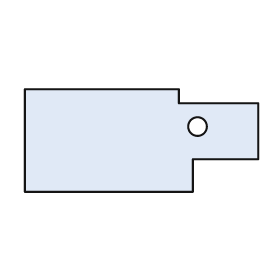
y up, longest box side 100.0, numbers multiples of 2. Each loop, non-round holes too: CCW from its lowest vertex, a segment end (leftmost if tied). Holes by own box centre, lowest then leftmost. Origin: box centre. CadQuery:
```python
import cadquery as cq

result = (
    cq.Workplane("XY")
    .moveTo(-50.0, -22.0)
    .lineTo(22.0, -22.0)
    .lineTo(22.0, -8.0)
    .lineTo(50.0, -8.0)
    .lineTo(50.0, 16.0)
    .lineTo(16.0, 16.0)
    .lineTo(16.0, 22.0)
    .lineTo(-50.0, 22.0)
    .close()
    .moveTo(24.0, 6.0)
    .circle(4.0)
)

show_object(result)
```